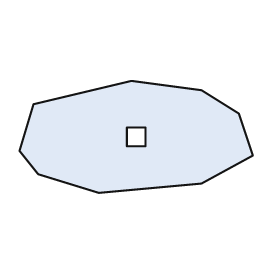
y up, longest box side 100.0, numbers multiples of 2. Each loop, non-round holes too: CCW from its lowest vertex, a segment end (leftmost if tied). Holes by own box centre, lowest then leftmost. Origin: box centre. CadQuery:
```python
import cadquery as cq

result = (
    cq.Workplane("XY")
    .moveTo(-16.0, -24.0)
    .lineTo(28.0, -20.0)
    .lineTo(50.0, -8.0)
    .lineTo(44.0, 10.0)
    .lineTo(28.0, 20.0)
    .lineTo(-2.0, 24.0)
    .lineTo(-44.0, 14.0)
    .lineTo(-50.0, -6.0)
    .lineTo(-42.0, -16.0)
    .close()
    .moveTo(-4.0, -4.0)
    .lineTo(4.0, -4.0)
    .lineTo(4.0, 4.0)
    .lineTo(-4.0, 4.0)
    .close()
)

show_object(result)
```